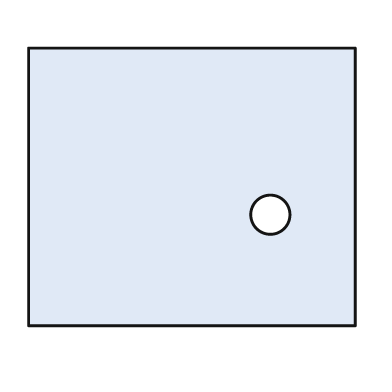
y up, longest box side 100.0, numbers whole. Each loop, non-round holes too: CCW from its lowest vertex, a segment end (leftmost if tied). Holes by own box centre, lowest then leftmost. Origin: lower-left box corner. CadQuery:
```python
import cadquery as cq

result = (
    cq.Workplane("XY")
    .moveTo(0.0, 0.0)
    .lineTo(100.0, 0.0)
    .lineTo(100.0, 85.0)
    .lineTo(0.0, 85.0)
    .close()
    .moveTo(74.0, 34.0)
    .circle(6.0)
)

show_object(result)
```